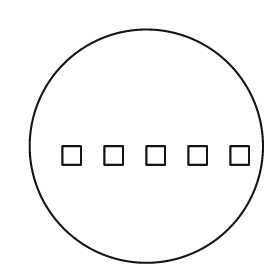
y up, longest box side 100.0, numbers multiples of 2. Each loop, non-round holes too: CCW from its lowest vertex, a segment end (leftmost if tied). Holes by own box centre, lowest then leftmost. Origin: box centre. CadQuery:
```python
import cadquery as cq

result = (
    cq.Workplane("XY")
    .moveTo(0.0, 0.0)
    .circle(50.0)
    .moveTo(-36.0, -8.0)
    .lineTo(-28.0, -8.0)
    .lineTo(-28.0, 0.0)
    .lineTo(-36.0, 0.0)
    .close()
    .moveTo(-18.0, -8.0)
    .lineTo(-10.0, -8.0)
    .lineTo(-10.0, 0.0)
    .lineTo(-18.0, 0.0)
    .close()
    .moveTo(0.0, -8.0)
    .lineTo(8.0, -8.0)
    .lineTo(8.0, 0.0)
    .lineTo(0.0, 0.0)
    .close()
    .moveTo(18.0, -8.0)
    .lineTo(26.0, -8.0)
    .lineTo(26.0, 0.0)
    .lineTo(18.0, 0.0)
    .close()
    .moveTo(36.0, -8.0)
    .lineTo(44.0, -8.0)
    .lineTo(44.0, 0.0)
    .lineTo(36.0, 0.0)
    .close()
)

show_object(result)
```